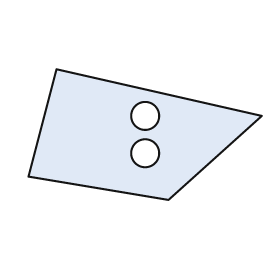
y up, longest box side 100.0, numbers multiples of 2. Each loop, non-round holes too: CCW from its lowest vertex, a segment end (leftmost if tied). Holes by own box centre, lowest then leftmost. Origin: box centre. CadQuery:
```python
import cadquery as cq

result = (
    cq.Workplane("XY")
    .moveTo(10.0, -28.0)
    .lineTo(50.0, 8.0)
    .lineTo(-38.0, 28.0)
    .lineTo(-50.0, -18.0)
    .close()
    .moveTo(0.0, -8.0)
    .circle(6.0)
    .moveTo(0.0, 8.0)
    .circle(6.0)
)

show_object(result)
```